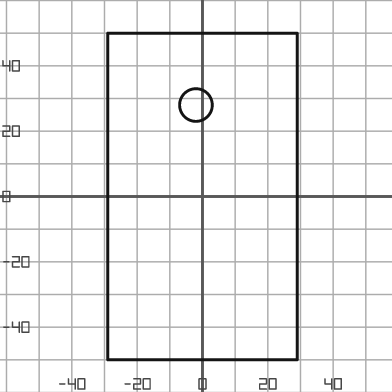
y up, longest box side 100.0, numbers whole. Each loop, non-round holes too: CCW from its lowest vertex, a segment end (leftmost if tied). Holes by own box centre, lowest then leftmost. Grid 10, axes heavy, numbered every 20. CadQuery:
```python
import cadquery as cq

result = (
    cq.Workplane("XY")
    .moveTo(-29.0, -50.0)
    .lineTo(29.0, -50.0)
    .lineTo(29.0, 50.0)
    .lineTo(-29.0, 50.0)
    .close()
    .moveTo(-2.0, 28.0)
    .circle(5.0)
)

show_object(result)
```